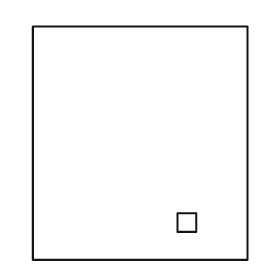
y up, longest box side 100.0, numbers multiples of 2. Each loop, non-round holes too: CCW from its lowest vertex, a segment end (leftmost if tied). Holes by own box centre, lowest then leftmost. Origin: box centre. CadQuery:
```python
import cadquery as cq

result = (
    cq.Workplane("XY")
    .moveTo(-46.0, -50.0)
    .lineTo(46.0, -50.0)
    .lineTo(46.0, 50.0)
    .lineTo(-46.0, 50.0)
    .close()
    .moveTo(16.0, -38.0)
    .lineTo(24.0, -38.0)
    .lineTo(24.0, -30.0)
    .lineTo(16.0, -30.0)
    .close()
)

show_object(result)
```